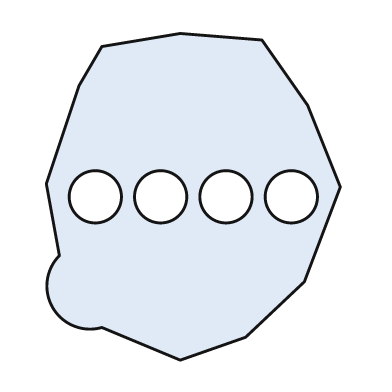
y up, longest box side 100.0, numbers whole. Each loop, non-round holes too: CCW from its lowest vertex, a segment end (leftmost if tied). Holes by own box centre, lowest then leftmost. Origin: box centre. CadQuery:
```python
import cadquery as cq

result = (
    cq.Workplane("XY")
    .moveTo(-4.0, -50.0)
    .lineTo(16.0, -43.0)
    .lineTo(34.0, -26.0)
    .lineTo(45.0, 3.0)
    .lineTo(35.0, 28.0)
    .lineTo(21.0, 48.0)
    .lineTo(-4.0, 50.0)
    .lineTo(-28.0, 46.0)
    .lineTo(-35.0, 34.0)
    .lineTo(-45.0, 4.0)
    .lineTo(-41.0, -18.0)
    .threePointArc((-43.0, -34.0), (-28.0, -40.0))
    .close()
    .moveTo(-30.0, 0.0)
    .circle(8.0)
    .moveTo(-10.0, 0.0)
    .circle(8.0)
    .moveTo(10.0, 0.0)
    .circle(8.0)
    .moveTo(30.0, 0.0)
    .circle(8.0)
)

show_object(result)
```